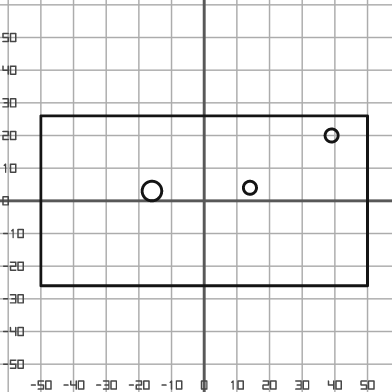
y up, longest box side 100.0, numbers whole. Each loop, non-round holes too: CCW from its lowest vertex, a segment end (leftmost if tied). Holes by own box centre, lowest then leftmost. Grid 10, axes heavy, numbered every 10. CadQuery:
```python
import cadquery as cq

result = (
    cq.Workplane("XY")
    .moveTo(-50.0, -26.0)
    .lineTo(50.0, -26.0)
    .lineTo(50.0, 26.0)
    .lineTo(-50.0, 26.0)
    .close()
    .moveTo(-16.0, 3.0)
    .circle(3.0)
    .moveTo(14.0, 4.0)
    .circle(2.0)
    .moveTo(39.0, 20.0)
    .circle(2.0)
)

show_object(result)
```